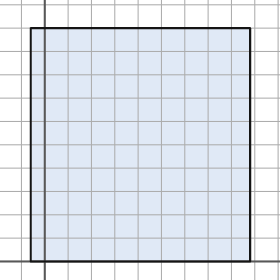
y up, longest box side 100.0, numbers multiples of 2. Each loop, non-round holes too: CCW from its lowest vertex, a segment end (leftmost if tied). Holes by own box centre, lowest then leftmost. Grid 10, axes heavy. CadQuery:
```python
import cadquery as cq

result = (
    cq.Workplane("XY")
    .moveTo(-6.0, 0.0)
    .lineTo(88.0, 0.0)
    .lineTo(88.0, 100.0)
    .lineTo(-6.0, 100.0)
    .close()
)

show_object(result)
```